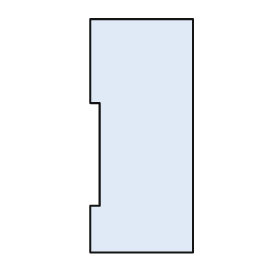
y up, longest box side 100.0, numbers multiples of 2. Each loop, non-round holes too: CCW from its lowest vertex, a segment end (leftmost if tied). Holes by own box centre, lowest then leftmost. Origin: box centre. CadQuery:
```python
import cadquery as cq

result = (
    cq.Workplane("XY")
    .moveTo(-22.0, -50.0)
    .lineTo(22.0, -50.0)
    .lineTo(22.0, 50.0)
    .lineTo(-22.0, 50.0)
    .lineTo(-22.0, 14.0)
    .lineTo(-18.0, 14.0)
    .lineTo(-18.0, -30.0)
    .lineTo(-22.0, -30.0)
    .close()
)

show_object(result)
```